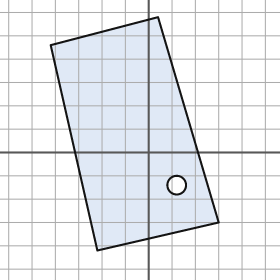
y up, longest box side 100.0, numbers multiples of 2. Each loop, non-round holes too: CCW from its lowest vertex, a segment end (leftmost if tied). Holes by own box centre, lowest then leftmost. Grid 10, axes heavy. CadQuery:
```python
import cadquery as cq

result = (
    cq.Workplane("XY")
    .moveTo(-22.0, -42.0)
    .lineTo(30.0, -30.0)
    .lineTo(4.0, 58.0)
    .lineTo(-42.0, 46.0)
    .close()
    .moveTo(12.0, -14.0)
    .circle(4.0)
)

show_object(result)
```